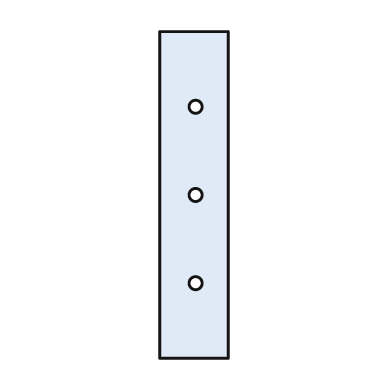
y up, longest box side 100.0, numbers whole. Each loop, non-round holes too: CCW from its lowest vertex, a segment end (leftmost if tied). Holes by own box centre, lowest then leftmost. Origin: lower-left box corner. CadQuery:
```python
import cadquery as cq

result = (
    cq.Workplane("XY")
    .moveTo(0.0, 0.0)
    .lineTo(21.0, 0.0)
    .lineTo(21.0, 100.0)
    .lineTo(0.0, 100.0)
    .close()
    .moveTo(11.0, 23.0)
    .circle(2.0)
    .moveTo(11.0, 50.0)
    .circle(2.0)
    .moveTo(11.0, 77.0)
    .circle(2.0)
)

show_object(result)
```